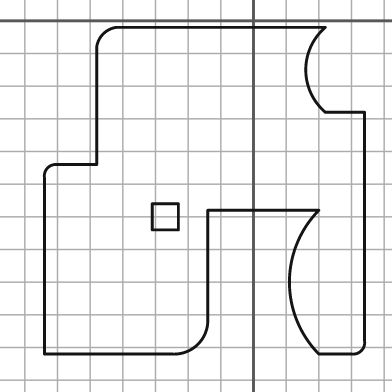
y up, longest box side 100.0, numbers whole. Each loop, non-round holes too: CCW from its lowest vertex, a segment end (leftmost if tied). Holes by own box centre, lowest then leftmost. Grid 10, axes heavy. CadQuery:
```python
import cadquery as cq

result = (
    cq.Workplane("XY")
    .moveTo(-64.0, -102.0)
    .lineTo(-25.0, -102.0)
    .threePointArc((-17.0, -99.0), (-14.0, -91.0))
    .lineTo(-14.0, -58.0)
    .lineTo(20.0, -58.0)
    .threePointArc((11.0, -80.0), (20.0, -102.0))
    .lineTo(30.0, -102.0)
    .threePointArc((33.0, -101.0), (34.0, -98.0))
    .lineTo(34.0, -28.0)
    .lineTo(22.0, -28.0)
    .threePointArc((16.0, -15.0), (22.0, -2.0))
    .lineTo(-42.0, -2.0)
    .threePointArc((-46.0, -4.0), (-48.0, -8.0))
    .lineTo(-48.0, -44.0)
    .lineTo(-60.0, -44.0)
    .threePointArc((-63.0, -45.0), (-64.0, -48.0))
    .close()
    .moveTo(-31.0, -64.0)
    .lineTo(-23.0, -64.0)
    .lineTo(-23.0, -56.0)
    .lineTo(-31.0, -56.0)
    .close()
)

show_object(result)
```